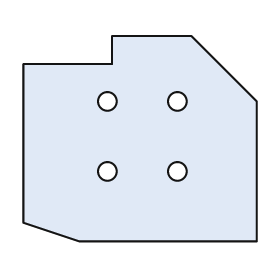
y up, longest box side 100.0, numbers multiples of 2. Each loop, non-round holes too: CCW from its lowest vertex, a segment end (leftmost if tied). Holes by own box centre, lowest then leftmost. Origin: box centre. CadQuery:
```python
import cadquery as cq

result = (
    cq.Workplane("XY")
    .moveTo(-26.0, -44.0)
    .lineTo(50.0, -44.0)
    .lineTo(50.0, 16.0)
    .lineTo(22.0, 44.0)
    .lineTo(-12.0, 44.0)
    .lineTo(-12.0, 32.0)
    .lineTo(-50.0, 32.0)
    .lineTo(-50.0, -36.0)
    .close()
    .moveTo(-14.0, -14.0)
    .circle(4.0)
    .moveTo(16.0, -14.0)
    .circle(4.0)
    .moveTo(-14.0, 16.0)
    .circle(4.0)
    .moveTo(16.0, 16.0)
    .circle(4.0)
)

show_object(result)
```